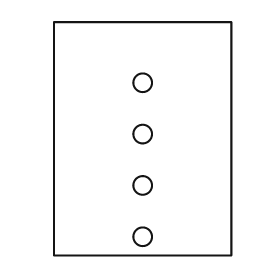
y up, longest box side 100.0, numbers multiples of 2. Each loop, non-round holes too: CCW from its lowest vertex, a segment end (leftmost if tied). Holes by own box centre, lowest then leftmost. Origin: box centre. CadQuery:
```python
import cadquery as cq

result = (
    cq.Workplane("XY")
    .moveTo(-38.0, -50.0)
    .lineTo(38.0, -50.0)
    .lineTo(38.0, 50.0)
    .lineTo(-38.0, 50.0)
    .close()
    .moveTo(0.0, -42.0)
    .circle(4.0)
    .moveTo(0.0, -20.0)
    .circle(4.0)
    .moveTo(0.0, 2.0)
    .circle(4.0)
    .moveTo(0.0, 24.0)
    .circle(4.0)
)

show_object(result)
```